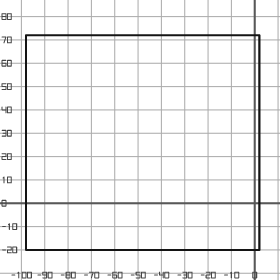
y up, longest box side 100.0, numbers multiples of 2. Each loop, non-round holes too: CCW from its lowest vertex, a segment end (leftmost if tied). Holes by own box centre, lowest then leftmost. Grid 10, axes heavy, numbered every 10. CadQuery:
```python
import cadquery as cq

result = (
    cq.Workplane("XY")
    .moveTo(-98.0, -20.0)
    .lineTo(2.0, -20.0)
    .lineTo(2.0, 72.0)
    .lineTo(-98.0, 72.0)
    .close()
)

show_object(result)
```